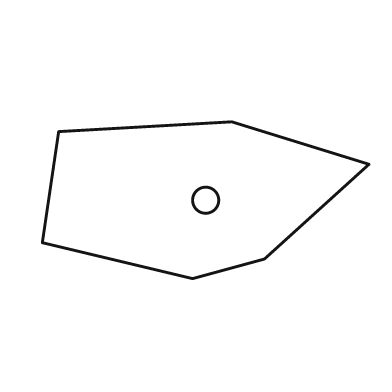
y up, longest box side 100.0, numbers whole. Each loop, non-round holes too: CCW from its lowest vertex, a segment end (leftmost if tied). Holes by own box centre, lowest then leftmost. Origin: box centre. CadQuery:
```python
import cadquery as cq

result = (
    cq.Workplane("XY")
    .moveTo(-4.0, -24.0)
    .lineTo(18.0, -18.0)
    .lineTo(50.0, 11.0)
    .lineTo(8.0, 24.0)
    .lineTo(-45.0, 21.0)
    .lineTo(-50.0, -13.0)
    .close()
    .moveTo(0.0, 0.0)
    .circle(4.0)
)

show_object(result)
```